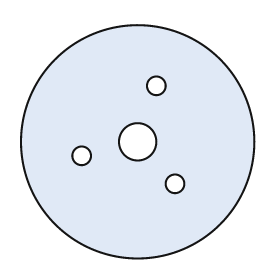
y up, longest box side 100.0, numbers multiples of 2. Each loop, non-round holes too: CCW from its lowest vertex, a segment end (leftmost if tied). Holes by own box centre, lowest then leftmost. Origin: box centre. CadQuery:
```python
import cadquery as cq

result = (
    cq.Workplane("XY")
    .moveTo(0.0, 0.0)
    .circle(50.0)
    .moveTo(16.0, -18.0)
    .circle(4.0)
    .moveTo(-24.0, -6.0)
    .circle(4.0)
    .moveTo(0.0, 0.0)
    .circle(8.0)
    .moveTo(8.0, 24.0)
    .circle(4.0)
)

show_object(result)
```